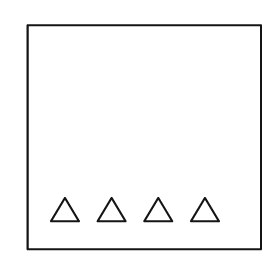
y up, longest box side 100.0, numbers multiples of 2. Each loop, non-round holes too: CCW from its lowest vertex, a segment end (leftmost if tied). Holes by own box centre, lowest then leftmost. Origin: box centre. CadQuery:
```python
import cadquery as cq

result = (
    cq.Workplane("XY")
    .moveTo(-50.0, -48.0)
    .lineTo(50.0, -48.0)
    .lineTo(50.0, 48.0)
    .lineTo(-50.0, 48.0)
    .close()
    .moveTo(-40.0, -36.0)
    .lineTo(-28.0, -36.0)
    .lineTo(-34.0, -26.0)
    .close()
    .moveTo(-20.0, -36.0)
    .lineTo(-8.0, -36.0)
    .lineTo(-14.0, -26.0)
    .close()
    .moveTo(0.0, -36.0)
    .lineTo(12.0, -36.0)
    .lineTo(6.0, -26.0)
    .close()
    .moveTo(20.0, -36.0)
    .lineTo(32.0, -36.0)
    .lineTo(26.0, -26.0)
    .close()
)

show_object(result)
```